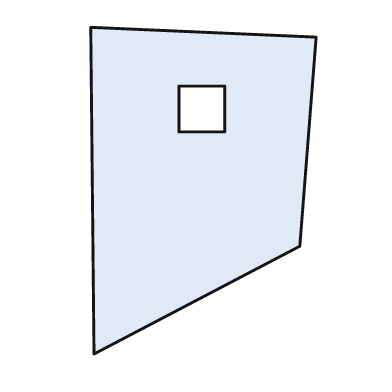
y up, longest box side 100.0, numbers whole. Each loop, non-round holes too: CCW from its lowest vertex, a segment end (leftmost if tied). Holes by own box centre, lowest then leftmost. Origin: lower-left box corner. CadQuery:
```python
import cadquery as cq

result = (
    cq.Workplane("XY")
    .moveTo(1.0, 0.0)
    .lineTo(64.0, 33.0)
    .lineTo(69.0, 97.0)
    .lineTo(0.0, 100.0)
    .close()
    .moveTo(27.0, 68.0)
    .lineTo(41.0, 68.0)
    .lineTo(41.0, 82.0)
    .lineTo(27.0, 82.0)
    .close()
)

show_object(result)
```